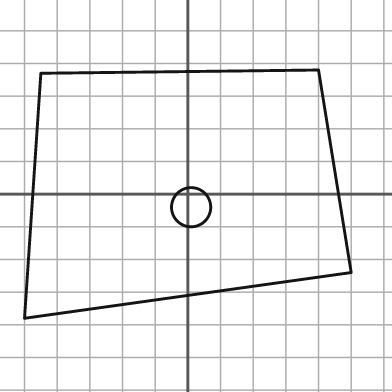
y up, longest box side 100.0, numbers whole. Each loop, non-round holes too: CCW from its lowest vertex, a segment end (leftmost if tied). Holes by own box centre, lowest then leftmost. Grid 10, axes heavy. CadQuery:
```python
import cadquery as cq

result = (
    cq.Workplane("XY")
    .moveTo(-50.0, -38.0)
    .lineTo(50.0, -24.0)
    .lineTo(40.0, 38.0)
    .lineTo(-45.0, 37.0)
    .close()
    .moveTo(1.0, -4.0)
    .circle(6.0)
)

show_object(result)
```